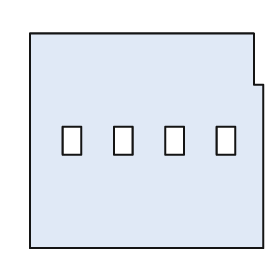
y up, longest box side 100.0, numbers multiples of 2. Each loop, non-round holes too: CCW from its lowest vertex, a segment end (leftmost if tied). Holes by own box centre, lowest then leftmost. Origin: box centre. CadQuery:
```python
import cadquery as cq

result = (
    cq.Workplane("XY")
    .moveTo(-50.0, -46.0)
    .lineTo(50.0, -46.0)
    .lineTo(50.0, 24.0)
    .lineTo(46.0, 24.0)
    .lineTo(46.0, 46.0)
    .lineTo(-50.0, 46.0)
    .close()
    .moveTo(-36.0, -6.0)
    .lineTo(-28.0, -6.0)
    .lineTo(-28.0, 6.0)
    .lineTo(-36.0, 6.0)
    .close()
    .moveTo(-14.0, -6.0)
    .lineTo(-6.0, -6.0)
    .lineTo(-6.0, 6.0)
    .lineTo(-14.0, 6.0)
    .close()
    .moveTo(8.0, -6.0)
    .lineTo(16.0, -6.0)
    .lineTo(16.0, 6.0)
    .lineTo(8.0, 6.0)
    .close()
    .moveTo(30.0, -6.0)
    .lineTo(38.0, -6.0)
    .lineTo(38.0, 6.0)
    .lineTo(30.0, 6.0)
    .close()
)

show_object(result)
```